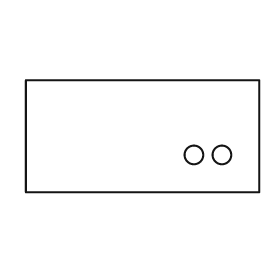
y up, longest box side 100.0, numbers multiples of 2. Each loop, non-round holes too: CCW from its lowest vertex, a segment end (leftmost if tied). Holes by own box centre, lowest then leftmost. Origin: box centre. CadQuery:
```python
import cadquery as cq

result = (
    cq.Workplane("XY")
    .moveTo(-50.0, -24.0)
    .lineTo(50.0, -24.0)
    .lineTo(50.0, 24.0)
    .lineTo(-50.0, 24.0)
    .close()
    .moveTo(22.0, -8.0)
    .circle(4.0)
    .moveTo(34.0, -8.0)
    .circle(4.0)
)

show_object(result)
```